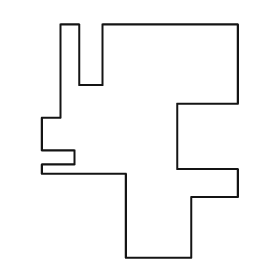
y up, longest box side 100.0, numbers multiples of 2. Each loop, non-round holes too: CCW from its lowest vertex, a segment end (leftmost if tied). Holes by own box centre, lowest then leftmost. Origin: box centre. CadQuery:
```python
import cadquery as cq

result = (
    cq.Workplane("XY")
    .moveTo(-6.0, -50.0)
    .lineTo(22.0, -50.0)
    .lineTo(22.0, -24.0)
    .lineTo(42.0, -24.0)
    .lineTo(42.0, -12.0)
    .lineTo(16.0, -12.0)
    .lineTo(16.0, 16.0)
    .lineTo(42.0, 16.0)
    .lineTo(42.0, 50.0)
    .lineTo(-16.0, 50.0)
    .lineTo(-16.0, 24.0)
    .lineTo(-26.0, 24.0)
    .lineTo(-26.0, 50.0)
    .lineTo(-34.0, 50.0)
    .lineTo(-34.0, 10.0)
    .lineTo(-42.0, 10.0)
    .lineTo(-42.0, -4.0)
    .lineTo(-28.0, -4.0)
    .lineTo(-28.0, -10.0)
    .lineTo(-42.0, -10.0)
    .lineTo(-42.0, -14.0)
    .lineTo(-6.0, -14.0)
    .close()
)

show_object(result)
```